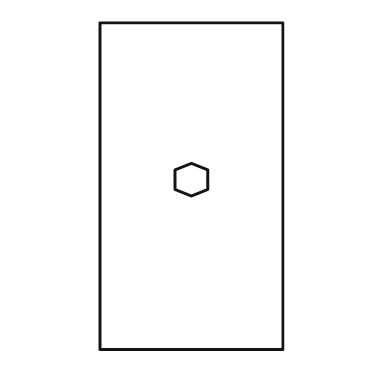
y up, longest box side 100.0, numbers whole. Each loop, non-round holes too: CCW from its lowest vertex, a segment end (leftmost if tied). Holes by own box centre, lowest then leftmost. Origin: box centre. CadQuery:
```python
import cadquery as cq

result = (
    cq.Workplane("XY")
    .moveTo(-28.0, -50.0)
    .lineTo(28.0, -50.0)
    .lineTo(28.0, 50.0)
    .lineTo(-28.0, 50.0)
    .close()
    .moveTo(0.0, -3.0)
    .lineTo(5.0, -1.0)
    .lineTo(5.0, 5.0)
    .lineTo(0.0, 7.0)
    .lineTo(-5.0, 5.0)
    .lineTo(-5.0, -1.0)
    .close()
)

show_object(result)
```